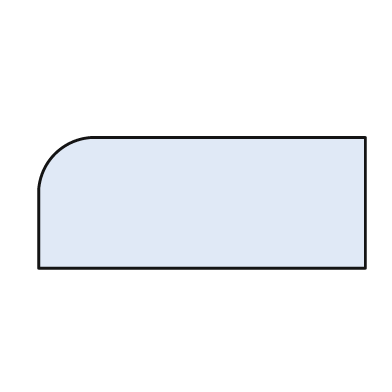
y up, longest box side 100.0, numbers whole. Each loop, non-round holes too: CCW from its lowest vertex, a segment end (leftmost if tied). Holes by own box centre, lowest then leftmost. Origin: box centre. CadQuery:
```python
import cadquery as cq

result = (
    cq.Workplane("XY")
    .moveTo(-50.0, -20.0)
    .lineTo(50.0, -20.0)
    .lineTo(50.0, 20.0)
    .lineTo(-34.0, 20.0)
    .threePointArc((-45.0, 15.0), (-50.0, 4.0))
    .close()
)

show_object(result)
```